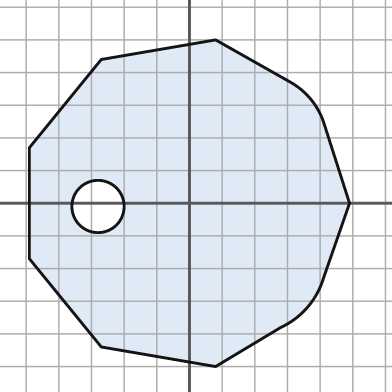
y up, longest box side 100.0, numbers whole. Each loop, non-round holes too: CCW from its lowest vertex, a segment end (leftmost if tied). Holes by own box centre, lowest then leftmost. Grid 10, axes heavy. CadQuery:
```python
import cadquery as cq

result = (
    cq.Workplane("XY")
    .moveTo(8.0, -50.0)
    .lineTo(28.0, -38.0)
    .threePointArc((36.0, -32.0), (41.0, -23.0))
    .lineTo(49.0, 0.0)
    .lineTo(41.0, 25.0)
    .threePointArc((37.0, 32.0), (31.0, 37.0))
    .lineTo(8.0, 50.0)
    .lineTo(-27.0, 44.0)
    .lineTo(-49.0, 17.0)
    .lineTo(-49.0, -17.0)
    .lineTo(-27.0, -44.0)
    .close()
    .moveTo(-28.0, -1.0)
    .circle(8.0)
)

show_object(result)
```